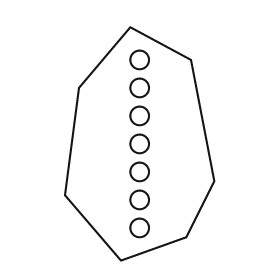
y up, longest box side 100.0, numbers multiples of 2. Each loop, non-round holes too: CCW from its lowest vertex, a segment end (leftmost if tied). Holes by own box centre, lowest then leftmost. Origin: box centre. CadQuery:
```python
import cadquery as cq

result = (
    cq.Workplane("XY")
    .moveTo(-8.0, -50.0)
    .lineTo(20.0, -40.0)
    .lineTo(32.0, -16.0)
    .lineTo(22.0, 36.0)
    .lineTo(-4.0, 50.0)
    .lineTo(-26.0, 24.0)
    .lineTo(-32.0, -22.0)
    .close()
    .moveTo(0.0, -36.0)
    .circle(4.0)
    .moveTo(0.0, -24.0)
    .circle(4.0)
    .moveTo(0.0, -12.0)
    .circle(4.0)
    .moveTo(0.0, 0.0)
    .circle(4.0)
    .moveTo(0.0, 12.0)
    .circle(4.0)
    .moveTo(0.0, 24.0)
    .circle(4.0)
    .moveTo(0.0, 36.0)
    .circle(4.0)
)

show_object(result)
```